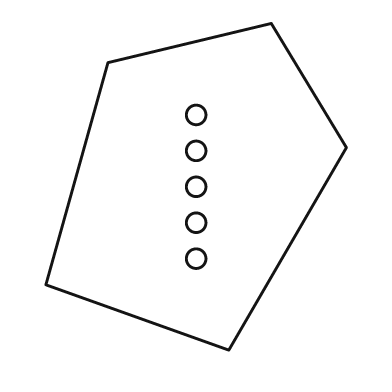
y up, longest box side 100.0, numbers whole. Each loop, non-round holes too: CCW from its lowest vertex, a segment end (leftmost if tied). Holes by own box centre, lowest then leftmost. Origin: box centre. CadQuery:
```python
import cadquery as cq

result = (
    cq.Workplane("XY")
    .moveTo(10.0, -50.0)
    .lineTo(46.0, 12.0)
    .lineTo(23.0, 50.0)
    .lineTo(-27.0, 38.0)
    .lineTo(-46.0, -30.0)
    .close()
    .moveTo(0.0, -22.0)
    .circle(3.0)
    .moveTo(0.0, -11.0)
    .circle(3.0)
    .moveTo(0.0, 0.0)
    .circle(3.0)
    .moveTo(0.0, 11.0)
    .circle(3.0)
    .moveTo(0.0, 22.0)
    .circle(3.0)
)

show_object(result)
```